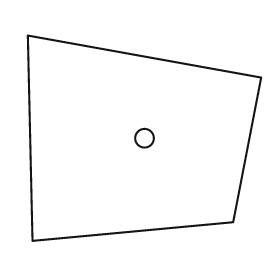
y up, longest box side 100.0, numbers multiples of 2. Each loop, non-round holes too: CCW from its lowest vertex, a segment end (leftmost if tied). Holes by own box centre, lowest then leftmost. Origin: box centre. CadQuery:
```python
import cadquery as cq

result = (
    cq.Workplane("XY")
    .moveTo(-48.0, -44.0)
    .lineTo(38.0, -36.0)
    .lineTo(50.0, 26.0)
    .lineTo(-50.0, 44.0)
    .close()
    .moveTo(0.0, 0.0)
    .circle(4.0)
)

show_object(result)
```